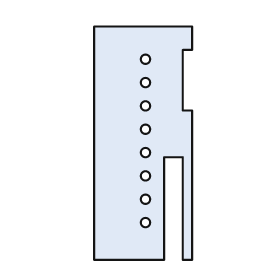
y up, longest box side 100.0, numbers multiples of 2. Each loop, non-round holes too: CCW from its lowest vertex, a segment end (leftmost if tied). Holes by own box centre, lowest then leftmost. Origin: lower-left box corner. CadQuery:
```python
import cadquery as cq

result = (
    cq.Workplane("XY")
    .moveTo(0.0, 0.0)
    .lineTo(30.0, 0.0)
    .lineTo(30.0, 44.0)
    .lineTo(38.0, 44.0)
    .lineTo(38.0, 0.0)
    .lineTo(42.0, 0.0)
    .lineTo(42.0, 64.0)
    .lineTo(38.0, 64.0)
    .lineTo(38.0, 90.0)
    .lineTo(42.0, 90.0)
    .lineTo(42.0, 100.0)
    .lineTo(0.0, 100.0)
    .close()
    .moveTo(22.0, 16.0)
    .circle(2.0)
    .moveTo(22.0, 26.0)
    .circle(2.0)
    .moveTo(22.0, 36.0)
    .circle(2.0)
    .moveTo(22.0, 46.0)
    .circle(2.0)
    .moveTo(22.0, 56.0)
    .circle(2.0)
    .moveTo(22.0, 66.0)
    .circle(2.0)
    .moveTo(22.0, 76.0)
    .circle(2.0)
    .moveTo(22.0, 86.0)
    .circle(2.0)
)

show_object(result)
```